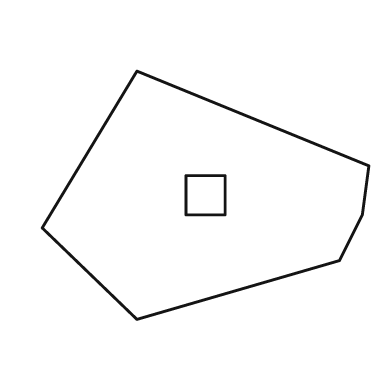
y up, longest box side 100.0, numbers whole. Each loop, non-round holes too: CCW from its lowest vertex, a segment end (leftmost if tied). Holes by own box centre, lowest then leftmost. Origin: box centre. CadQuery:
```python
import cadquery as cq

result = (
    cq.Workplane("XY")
    .moveTo(-21.0, -38.0)
    .lineTo(41.0, -20.0)
    .lineTo(48.0, -6.0)
    .lineTo(50.0, 9.0)
    .lineTo(-21.0, 38.0)
    .lineTo(-50.0, -10.0)
    .close()
    .moveTo(-6.0, -6.0)
    .lineTo(6.0, -6.0)
    .lineTo(6.0, 6.0)
    .lineTo(-6.0, 6.0)
    .close()
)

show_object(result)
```